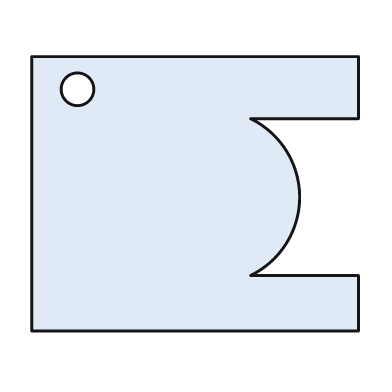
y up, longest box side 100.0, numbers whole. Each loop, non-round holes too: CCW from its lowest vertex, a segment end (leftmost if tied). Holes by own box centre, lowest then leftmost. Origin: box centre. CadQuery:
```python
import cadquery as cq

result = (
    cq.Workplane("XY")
    .moveTo(-50.0, -42.0)
    .lineTo(50.0, -42.0)
    .lineTo(50.0, -25.0)
    .lineTo(17.0, -25.0)
    .threePointArc((32.0, -1.0), (17.0, 23.0))
    .lineTo(50.0, 23.0)
    .lineTo(50.0, 42.0)
    .lineTo(-50.0, 42.0)
    .close()
    .moveTo(-36.0, 32.0)
    .circle(5.0)
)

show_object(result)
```